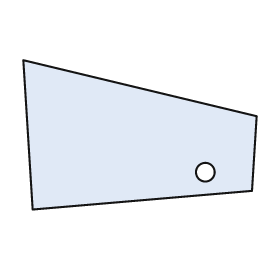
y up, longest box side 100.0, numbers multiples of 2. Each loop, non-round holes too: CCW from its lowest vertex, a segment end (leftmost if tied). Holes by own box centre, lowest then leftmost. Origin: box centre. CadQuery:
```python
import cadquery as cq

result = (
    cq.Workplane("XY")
    .moveTo(-46.0, -32.0)
    .lineTo(48.0, -24.0)
    .lineTo(50.0, 8.0)
    .lineTo(-50.0, 32.0)
    .close()
    .moveTo(28.0, -16.0)
    .circle(4.0)
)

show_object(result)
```